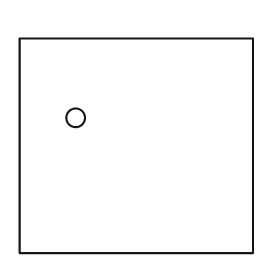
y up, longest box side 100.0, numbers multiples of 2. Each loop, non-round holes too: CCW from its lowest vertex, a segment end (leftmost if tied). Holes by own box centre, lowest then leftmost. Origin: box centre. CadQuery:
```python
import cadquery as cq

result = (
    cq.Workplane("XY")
    .moveTo(-50.0, -46.0)
    .lineTo(50.0, -46.0)
    .lineTo(50.0, 46.0)
    .lineTo(-50.0, 46.0)
    .close()
    .moveTo(-26.0, 12.0)
    .circle(4.0)
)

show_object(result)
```